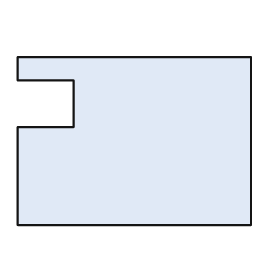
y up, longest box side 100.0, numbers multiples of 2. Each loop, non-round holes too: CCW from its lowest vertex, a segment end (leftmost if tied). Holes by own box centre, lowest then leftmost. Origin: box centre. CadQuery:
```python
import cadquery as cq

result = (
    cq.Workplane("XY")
    .moveTo(-50.0, -36.0)
    .lineTo(50.0, -36.0)
    .lineTo(50.0, 36.0)
    .lineTo(-50.0, 36.0)
    .lineTo(-50.0, 26.0)
    .lineTo(-26.0, 26.0)
    .lineTo(-26.0, 6.0)
    .lineTo(-50.0, 6.0)
    .close()
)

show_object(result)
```